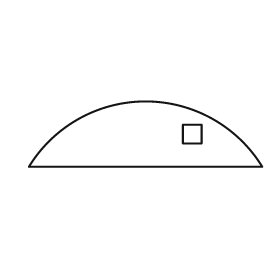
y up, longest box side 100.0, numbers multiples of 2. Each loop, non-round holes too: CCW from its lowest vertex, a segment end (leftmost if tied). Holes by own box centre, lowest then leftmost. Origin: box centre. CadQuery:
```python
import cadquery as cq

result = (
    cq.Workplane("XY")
    .moveTo(-50.0, -14.0)
    .lineTo(50.0, -14.0)
    .threePointArc((0.0, 14.0), (-50.0, -14.0))
    .close()
    .moveTo(16.0, -4.0)
    .lineTo(24.0, -4.0)
    .lineTo(24.0, 4.0)
    .lineTo(16.0, 4.0)
    .close()
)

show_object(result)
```